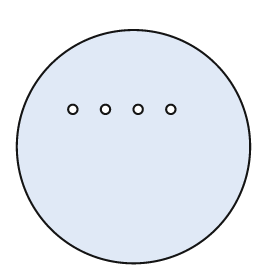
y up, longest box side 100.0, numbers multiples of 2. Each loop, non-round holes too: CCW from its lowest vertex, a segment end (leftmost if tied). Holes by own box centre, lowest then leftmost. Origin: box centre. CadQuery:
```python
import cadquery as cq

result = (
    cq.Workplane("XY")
    .moveTo(0.0, 0.0)
    .circle(50.0)
    .moveTo(-26.0, 16.0)
    .circle(2.0)
    .moveTo(-12.0, 16.0)
    .circle(2.0)
    .moveTo(2.0, 16.0)
    .circle(2.0)
    .moveTo(16.0, 16.0)
    .circle(2.0)
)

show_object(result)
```